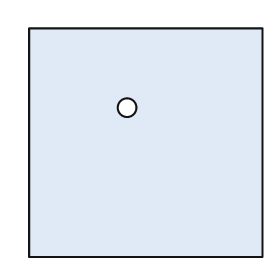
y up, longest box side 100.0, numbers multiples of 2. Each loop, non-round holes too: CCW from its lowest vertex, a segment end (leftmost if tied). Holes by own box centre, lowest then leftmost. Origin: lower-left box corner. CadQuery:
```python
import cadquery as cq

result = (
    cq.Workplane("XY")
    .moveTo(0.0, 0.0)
    .lineTo(100.0, 0.0)
    .lineTo(100.0, 98.0)
    .lineTo(0.0, 98.0)
    .close()
    .moveTo(42.0, 64.0)
    .circle(4.0)
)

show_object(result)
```